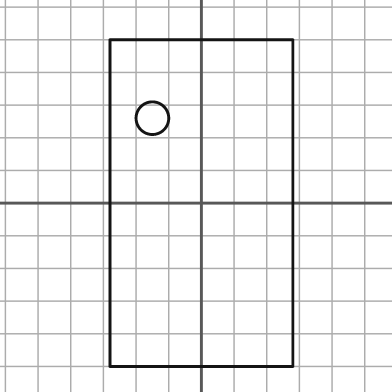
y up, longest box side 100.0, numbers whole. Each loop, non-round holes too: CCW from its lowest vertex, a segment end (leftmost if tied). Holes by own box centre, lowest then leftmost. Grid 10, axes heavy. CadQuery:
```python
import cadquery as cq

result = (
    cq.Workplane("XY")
    .moveTo(-28.0, -50.0)
    .lineTo(28.0, -50.0)
    .lineTo(28.0, 50.0)
    .lineTo(-28.0, 50.0)
    .close()
    .moveTo(-15.0, 26.0)
    .circle(5.0)
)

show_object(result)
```